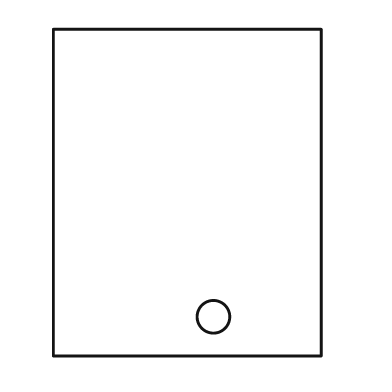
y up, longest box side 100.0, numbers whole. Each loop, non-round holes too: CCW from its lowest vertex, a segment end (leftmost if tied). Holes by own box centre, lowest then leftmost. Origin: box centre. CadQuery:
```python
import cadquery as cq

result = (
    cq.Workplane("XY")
    .moveTo(-41.0, -50.0)
    .lineTo(41.0, -50.0)
    .lineTo(41.0, 50.0)
    .lineTo(-41.0, 50.0)
    .close()
    .moveTo(8.0, -38.0)
    .circle(5.0)
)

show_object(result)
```